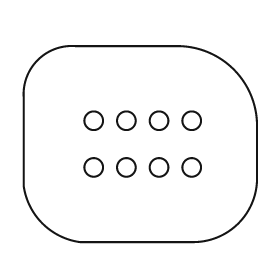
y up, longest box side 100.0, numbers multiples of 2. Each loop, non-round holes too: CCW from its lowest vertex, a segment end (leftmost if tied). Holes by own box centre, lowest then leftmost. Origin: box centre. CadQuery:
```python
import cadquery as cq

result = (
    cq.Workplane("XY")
    .moveTo(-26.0, -42.0)
    .lineTo(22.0, -42.0)
    .threePointArc((42.0, -34.0), (50.0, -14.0))
    .lineTo(50.0, 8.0)
    .threePointArc((40.0, 32.0), (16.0, 42.0))
    .lineTo(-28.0, 42.0)
    .threePointArc((-44.0, 36.0), (-50.0, 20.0))
    .lineTo(-50.0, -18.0)
    .threePointArc((-42.0, -34.0), (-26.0, -42.0))
    .close()
    .moveTo(-20.0, -10.0)
    .circle(4.0)
    .moveTo(-6.0, -10.0)
    .circle(4.0)
    .moveTo(8.0, -10.0)
    .circle(4.0)
    .moveTo(22.0, -10.0)
    .circle(4.0)
    .moveTo(-20.0, 10.0)
    .circle(4.0)
    .moveTo(-6.0, 10.0)
    .circle(4.0)
    .moveTo(8.0, 10.0)
    .circle(4.0)
    .moveTo(22.0, 10.0)
    .circle(4.0)
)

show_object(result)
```